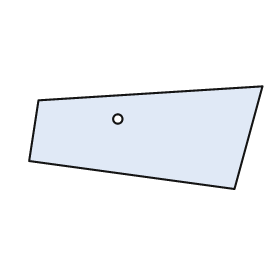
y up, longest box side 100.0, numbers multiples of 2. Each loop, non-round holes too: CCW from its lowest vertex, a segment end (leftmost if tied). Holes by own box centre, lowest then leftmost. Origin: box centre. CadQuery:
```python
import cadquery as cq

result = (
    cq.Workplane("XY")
    .moveTo(38.0, -22.0)
    .lineTo(50.0, 22.0)
    .lineTo(-46.0, 16.0)
    .lineTo(-50.0, -10.0)
    .close()
    .moveTo(-12.0, 8.0)
    .circle(2.0)
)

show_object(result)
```